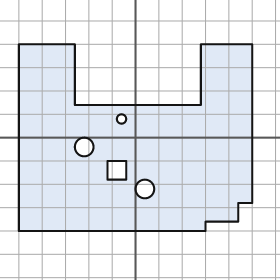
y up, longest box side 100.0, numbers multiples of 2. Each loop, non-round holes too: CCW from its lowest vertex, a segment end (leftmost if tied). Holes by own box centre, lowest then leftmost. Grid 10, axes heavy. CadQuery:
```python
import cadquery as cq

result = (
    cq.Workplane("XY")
    .moveTo(-50.0, -40.0)
    .lineTo(30.0, -40.0)
    .lineTo(30.0, -36.0)
    .lineTo(44.0, -36.0)
    .lineTo(44.0, -28.0)
    .lineTo(50.0, -28.0)
    .lineTo(50.0, 40.0)
    .lineTo(28.0, 40.0)
    .lineTo(28.0, 14.0)
    .lineTo(-26.0, 14.0)
    .lineTo(-26.0, 40.0)
    .lineTo(-50.0, 40.0)
    .close()
    .moveTo(4.0, -22.0)
    .circle(4.0)
    .moveTo(-12.0, -18.0)
    .lineTo(-4.0, -18.0)
    .lineTo(-4.0, -10.0)
    .lineTo(-12.0, -10.0)
    .close()
    .moveTo(-22.0, -4.0)
    .circle(4.0)
    .moveTo(-6.0, 8.0)
    .circle(2.0)
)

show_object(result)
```